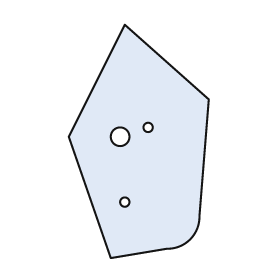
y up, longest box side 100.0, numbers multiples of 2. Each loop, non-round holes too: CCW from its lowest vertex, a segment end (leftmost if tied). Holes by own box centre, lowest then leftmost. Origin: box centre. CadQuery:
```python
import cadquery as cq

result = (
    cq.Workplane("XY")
    .moveTo(-12.0, -50.0)
    .lineTo(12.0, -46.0)
    .threePointArc((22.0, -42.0), (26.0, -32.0))
    .lineTo(30.0, 18.0)
    .lineTo(-6.0, 50.0)
    .lineTo(-30.0, 2.0)
    .close()
    .moveTo(-6.0, -26.0)
    .circle(2.0)
    .moveTo(-8.0, 2.0)
    .circle(4.0)
    .moveTo(4.0, 6.0)
    .circle(2.0)
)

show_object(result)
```